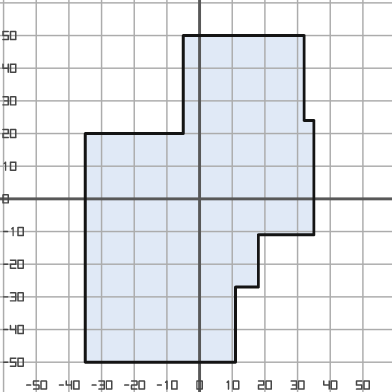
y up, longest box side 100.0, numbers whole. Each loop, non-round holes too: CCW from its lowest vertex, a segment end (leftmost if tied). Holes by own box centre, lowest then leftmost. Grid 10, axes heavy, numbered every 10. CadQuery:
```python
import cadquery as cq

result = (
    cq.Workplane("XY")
    .moveTo(-35.0, -50.0)
    .lineTo(11.0, -50.0)
    .lineTo(11.0, -27.0)
    .lineTo(18.0, -27.0)
    .lineTo(18.0, -11.0)
    .lineTo(35.0, -11.0)
    .lineTo(35.0, 24.0)
    .lineTo(32.0, 24.0)
    .lineTo(32.0, 50.0)
    .lineTo(-5.0, 50.0)
    .lineTo(-5.0, 20.0)
    .lineTo(-35.0, 20.0)
    .close()
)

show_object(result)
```